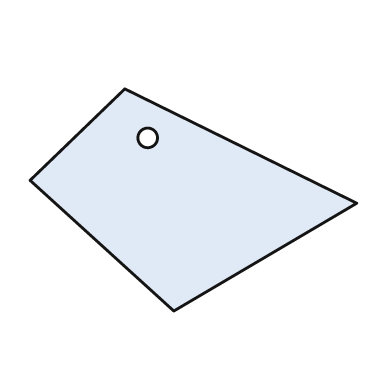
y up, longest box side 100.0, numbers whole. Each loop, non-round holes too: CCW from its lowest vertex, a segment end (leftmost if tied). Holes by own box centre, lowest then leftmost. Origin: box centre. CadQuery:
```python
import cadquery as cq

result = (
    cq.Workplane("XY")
    .moveTo(-6.0, -34.0)
    .lineTo(50.0, -1.0)
    .lineTo(-21.0, 34.0)
    .lineTo(-50.0, 6.0)
    .close()
    .moveTo(-14.0, 19.0)
    .circle(3.0)
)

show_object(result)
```